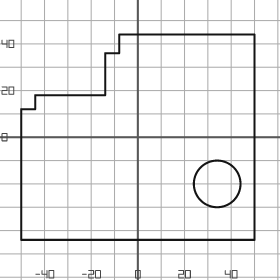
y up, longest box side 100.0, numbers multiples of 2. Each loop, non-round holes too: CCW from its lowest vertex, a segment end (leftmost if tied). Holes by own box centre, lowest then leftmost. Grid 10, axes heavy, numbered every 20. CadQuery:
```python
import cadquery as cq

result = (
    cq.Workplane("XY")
    .moveTo(-50.0, -44.0)
    .lineTo(50.0, -44.0)
    .lineTo(50.0, 44.0)
    .lineTo(-8.0, 44.0)
    .lineTo(-8.0, 36.0)
    .lineTo(-14.0, 36.0)
    .lineTo(-14.0, 18.0)
    .lineTo(-44.0, 18.0)
    .lineTo(-44.0, 12.0)
    .lineTo(-50.0, 12.0)
    .close()
    .moveTo(34.0, -20.0)
    .circle(10.0)
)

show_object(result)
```